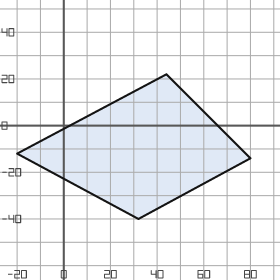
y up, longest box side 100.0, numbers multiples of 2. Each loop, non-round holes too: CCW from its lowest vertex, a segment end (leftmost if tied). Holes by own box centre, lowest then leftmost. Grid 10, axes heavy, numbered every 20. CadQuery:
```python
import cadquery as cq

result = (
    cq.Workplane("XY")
    .moveTo(32.0, -40.0)
    .lineTo(80.0, -14.0)
    .lineTo(44.0, 22.0)
    .lineTo(-20.0, -12.0)
    .close()
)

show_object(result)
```